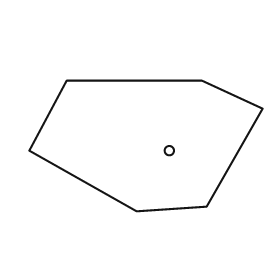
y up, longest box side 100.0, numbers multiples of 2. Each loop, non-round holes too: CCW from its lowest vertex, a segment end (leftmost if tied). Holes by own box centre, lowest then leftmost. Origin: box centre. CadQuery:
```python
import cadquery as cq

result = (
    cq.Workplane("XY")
    .moveTo(-4.0, -28.0)
    .lineTo(26.0, -26.0)
    .lineTo(50.0, 16.0)
    .lineTo(24.0, 28.0)
    .lineTo(-34.0, 28.0)
    .lineTo(-50.0, -2.0)
    .close()
    .moveTo(10.0, -2.0)
    .circle(2.0)
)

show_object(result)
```